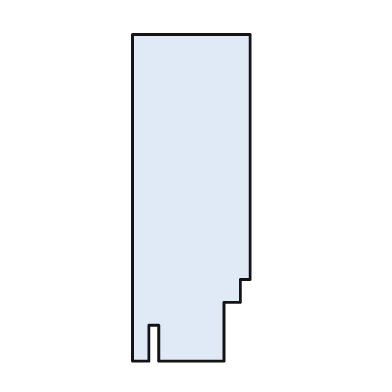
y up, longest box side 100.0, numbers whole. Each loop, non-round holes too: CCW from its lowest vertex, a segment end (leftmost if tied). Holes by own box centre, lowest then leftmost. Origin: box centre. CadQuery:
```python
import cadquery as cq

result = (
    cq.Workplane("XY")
    .moveTo(-18.0, -50.0)
    .lineTo(-13.0, -50.0)
    .lineTo(-13.0, -39.0)
    .lineTo(-10.0, -39.0)
    .lineTo(-10.0, -50.0)
    .lineTo(10.0, -50.0)
    .lineTo(10.0, -32.0)
    .lineTo(15.0, -32.0)
    .lineTo(15.0, -25.0)
    .lineTo(18.0, -25.0)
    .lineTo(18.0, 50.0)
    .lineTo(-18.0, 50.0)
    .close()
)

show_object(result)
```